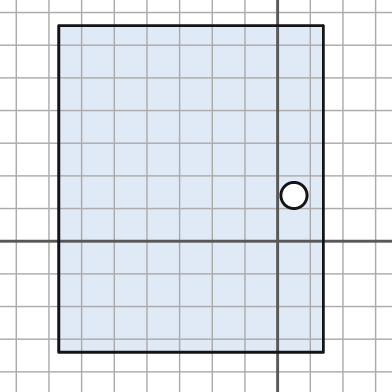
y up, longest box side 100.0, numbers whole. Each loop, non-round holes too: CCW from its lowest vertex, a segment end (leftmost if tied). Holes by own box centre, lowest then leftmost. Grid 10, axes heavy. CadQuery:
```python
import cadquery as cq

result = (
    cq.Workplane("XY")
    .moveTo(-67.0, -34.0)
    .lineTo(14.0, -34.0)
    .lineTo(14.0, 66.0)
    .lineTo(-67.0, 66.0)
    .close()
    .moveTo(5.0, 14.0)
    .circle(4.0)
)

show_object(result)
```